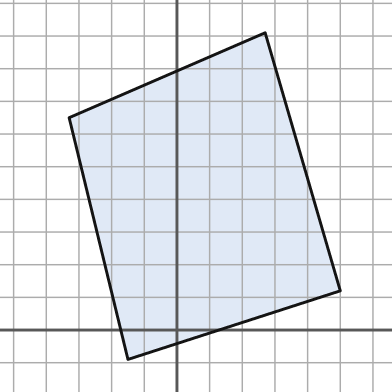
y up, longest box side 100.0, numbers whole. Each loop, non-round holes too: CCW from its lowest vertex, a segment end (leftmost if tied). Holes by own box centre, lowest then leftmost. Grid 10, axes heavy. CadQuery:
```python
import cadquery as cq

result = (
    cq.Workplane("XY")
    .moveTo(-15.0, -9.0)
    .lineTo(50.0, 12.0)
    .lineTo(27.0, 91.0)
    .lineTo(-33.0, 65.0)
    .close()
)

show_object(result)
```